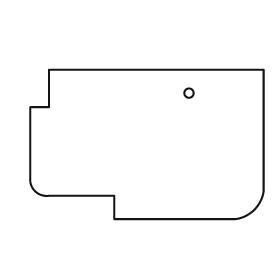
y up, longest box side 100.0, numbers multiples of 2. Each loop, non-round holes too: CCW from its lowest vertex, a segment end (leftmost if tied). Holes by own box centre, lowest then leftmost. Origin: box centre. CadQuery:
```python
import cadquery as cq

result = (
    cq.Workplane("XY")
    .moveTo(-14.0, -32.0)
    .lineTo(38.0, -32.0)
    .threePointArc((46.0, -28.0), (50.0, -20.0))
    .lineTo(50.0, 32.0)
    .lineTo(-42.0, 32.0)
    .lineTo(-42.0, 16.0)
    .lineTo(-50.0, 16.0)
    .lineTo(-50.0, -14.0)
    .threePointArc((-48.0, -20.0), (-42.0, -22.0))
    .lineTo(-14.0, -22.0)
    .close()
    .moveTo(18.0, 22.0)
    .circle(2.0)
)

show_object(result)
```